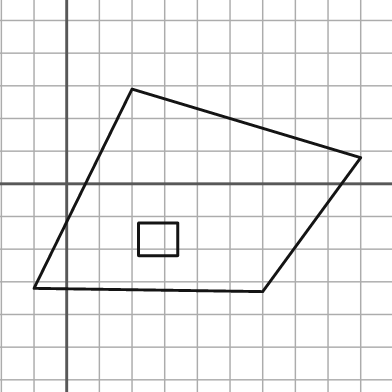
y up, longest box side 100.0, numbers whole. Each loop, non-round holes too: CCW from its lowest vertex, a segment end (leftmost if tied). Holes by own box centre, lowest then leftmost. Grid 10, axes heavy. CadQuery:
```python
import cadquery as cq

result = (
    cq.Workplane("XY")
    .moveTo(60.0, -33.0)
    .lineTo(90.0, 8.0)
    .lineTo(20.0, 29.0)
    .lineTo(-10.0, -32.0)
    .close()
    .moveTo(22.0, -22.0)
    .lineTo(34.0, -22.0)
    .lineTo(34.0, -12.0)
    .lineTo(22.0, -12.0)
    .close()
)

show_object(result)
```